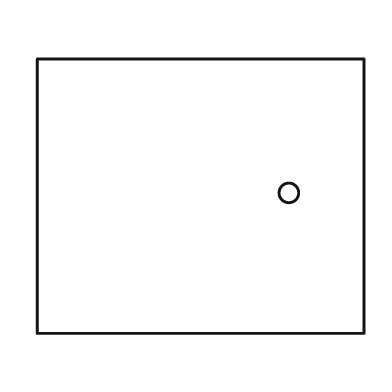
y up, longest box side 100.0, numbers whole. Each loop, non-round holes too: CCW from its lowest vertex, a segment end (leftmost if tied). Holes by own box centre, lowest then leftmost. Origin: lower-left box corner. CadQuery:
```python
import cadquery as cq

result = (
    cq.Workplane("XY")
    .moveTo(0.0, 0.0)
    .lineTo(100.0, 0.0)
    .lineTo(100.0, 84.0)
    .lineTo(0.0, 84.0)
    .close()
    .moveTo(77.0, 43.0)
    .circle(3.0)
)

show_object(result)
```